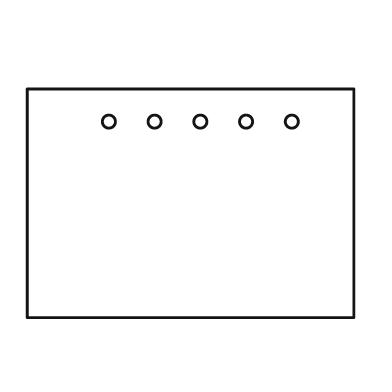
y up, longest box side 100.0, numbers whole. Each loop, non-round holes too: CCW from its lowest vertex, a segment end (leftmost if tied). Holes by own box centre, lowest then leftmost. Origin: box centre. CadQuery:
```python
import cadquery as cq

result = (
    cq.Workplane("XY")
    .moveTo(-50.0, -35.0)
    .lineTo(50.0, -35.0)
    .lineTo(50.0, 35.0)
    .lineTo(-50.0, 35.0)
    .close()
    .moveTo(-25.0, 25.0)
    .circle(2.0)
    .moveTo(-11.0, 25.0)
    .circle(2.0)
    .moveTo(3.0, 25.0)
    .circle(2.0)
    .moveTo(17.0, 25.0)
    .circle(2.0)
    .moveTo(31.0, 25.0)
    .circle(2.0)
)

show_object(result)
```